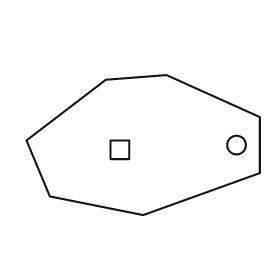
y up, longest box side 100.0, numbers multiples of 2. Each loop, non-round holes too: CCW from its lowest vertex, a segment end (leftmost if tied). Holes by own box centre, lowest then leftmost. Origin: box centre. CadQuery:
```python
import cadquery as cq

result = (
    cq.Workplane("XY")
    .moveTo(0.0, -30.0)
    .lineTo(50.0, -12.0)
    .lineTo(50.0, 12.0)
    .lineTo(10.0, 30.0)
    .lineTo(-16.0, 28.0)
    .lineTo(-50.0, 2.0)
    .lineTo(-40.0, -22.0)
    .close()
    .moveTo(-14.0, -6.0)
    .lineTo(-6.0, -6.0)
    .lineTo(-6.0, 2.0)
    .lineTo(-14.0, 2.0)
    .close()
    .moveTo(40.0, 0.0)
    .circle(4.0)
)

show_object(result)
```